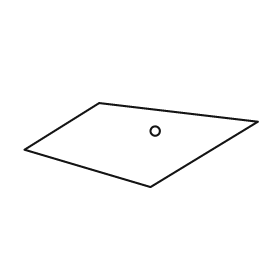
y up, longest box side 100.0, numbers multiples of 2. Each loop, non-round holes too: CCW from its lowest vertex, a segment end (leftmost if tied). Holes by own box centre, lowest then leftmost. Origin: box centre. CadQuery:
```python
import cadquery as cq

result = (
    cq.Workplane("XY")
    .moveTo(4.0, -18.0)
    .lineTo(50.0, 10.0)
    .lineTo(-18.0, 18.0)
    .lineTo(-50.0, -2.0)
    .close()
    .moveTo(6.0, 6.0)
    .circle(2.0)
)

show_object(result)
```